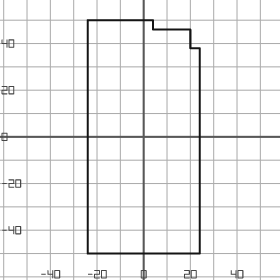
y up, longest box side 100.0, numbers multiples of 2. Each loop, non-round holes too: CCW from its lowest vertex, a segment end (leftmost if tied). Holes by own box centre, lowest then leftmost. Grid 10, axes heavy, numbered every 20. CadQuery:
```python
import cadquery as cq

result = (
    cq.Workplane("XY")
    .moveTo(-24.0, -50.0)
    .lineTo(24.0, -50.0)
    .lineTo(24.0, 38.0)
    .lineTo(20.0, 38.0)
    .lineTo(20.0, 46.0)
    .lineTo(4.0, 46.0)
    .lineTo(4.0, 50.0)
    .lineTo(-24.0, 50.0)
    .close()
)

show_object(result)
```